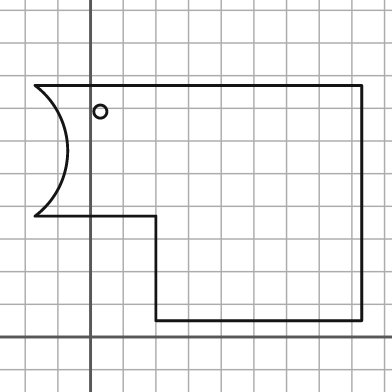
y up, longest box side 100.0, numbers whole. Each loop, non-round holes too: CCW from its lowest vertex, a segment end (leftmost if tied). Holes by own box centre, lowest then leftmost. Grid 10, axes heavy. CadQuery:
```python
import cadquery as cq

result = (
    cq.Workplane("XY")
    .moveTo(20.0, 5.0)
    .lineTo(83.0, 5.0)
    .lineTo(83.0, 77.0)
    .lineTo(-17.0, 77.0)
    .threePointArc((-7.0, 57.0), (-17.0, 37.0))
    .lineTo(20.0, 37.0)
    .close()
    .moveTo(3.0, 69.0)
    .circle(2.0)
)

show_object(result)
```